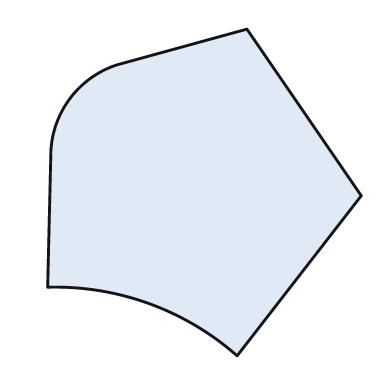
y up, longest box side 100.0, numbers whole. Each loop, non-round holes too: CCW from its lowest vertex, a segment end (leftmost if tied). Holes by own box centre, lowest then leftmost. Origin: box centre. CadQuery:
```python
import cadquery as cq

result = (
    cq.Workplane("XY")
    .moveTo(10.0, -50.0)
    .lineTo(48.0, -1.0)
    .lineTo(13.0, 50.0)
    .lineTo(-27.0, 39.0)
    .threePointArc((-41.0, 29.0), (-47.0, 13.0))
    .lineTo(-48.0, -29.0)
    .threePointArc((-17.0, -34.0), (10.0, -50.0))
    .close()
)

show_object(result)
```